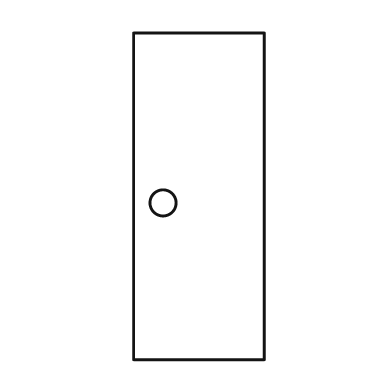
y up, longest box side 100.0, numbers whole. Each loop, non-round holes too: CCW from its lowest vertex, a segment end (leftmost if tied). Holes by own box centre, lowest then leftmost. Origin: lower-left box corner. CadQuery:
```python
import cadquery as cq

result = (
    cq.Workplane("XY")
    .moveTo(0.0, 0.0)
    .lineTo(40.0, 0.0)
    .lineTo(40.0, 100.0)
    .lineTo(0.0, 100.0)
    .close()
    .moveTo(9.0, 48.0)
    .circle(4.0)
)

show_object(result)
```